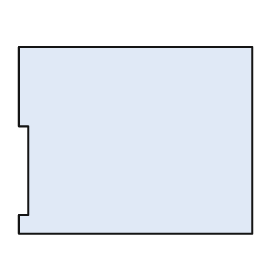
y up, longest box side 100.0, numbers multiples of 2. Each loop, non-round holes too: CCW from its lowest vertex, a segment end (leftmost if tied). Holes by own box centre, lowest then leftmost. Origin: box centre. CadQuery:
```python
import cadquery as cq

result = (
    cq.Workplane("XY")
    .moveTo(-50.0, -40.0)
    .lineTo(50.0, -40.0)
    .lineTo(50.0, 40.0)
    .lineTo(-50.0, 40.0)
    .lineTo(-50.0, 6.0)
    .lineTo(-46.0, 6.0)
    .lineTo(-46.0, -32.0)
    .lineTo(-50.0, -32.0)
    .close()
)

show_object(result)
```